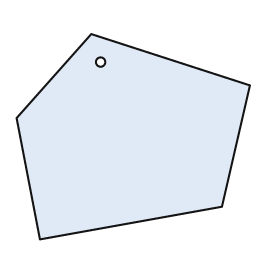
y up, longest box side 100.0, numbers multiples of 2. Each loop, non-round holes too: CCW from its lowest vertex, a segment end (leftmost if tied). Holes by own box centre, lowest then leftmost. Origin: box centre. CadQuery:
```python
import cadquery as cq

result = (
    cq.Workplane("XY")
    .moveTo(-40.0, -44.0)
    .lineTo(38.0, -30.0)
    .lineTo(50.0, 22.0)
    .lineTo(-18.0, 44.0)
    .lineTo(-50.0, 8.0)
    .close()
    .moveTo(-14.0, 32.0)
    .circle(2.0)
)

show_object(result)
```